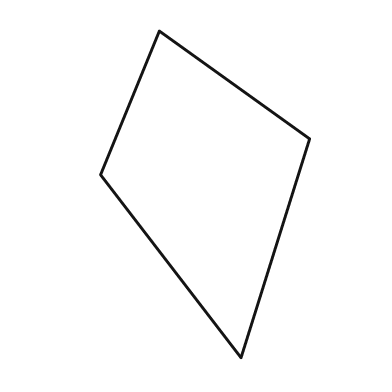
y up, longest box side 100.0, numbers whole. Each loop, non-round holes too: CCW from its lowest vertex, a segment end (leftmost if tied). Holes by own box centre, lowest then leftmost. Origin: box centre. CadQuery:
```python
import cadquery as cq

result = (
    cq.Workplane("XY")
    .moveTo(11.0, -50.0)
    .lineTo(32.0, 17.0)
    .lineTo(-14.0, 50.0)
    .lineTo(-32.0, 6.0)
    .close()
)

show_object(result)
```